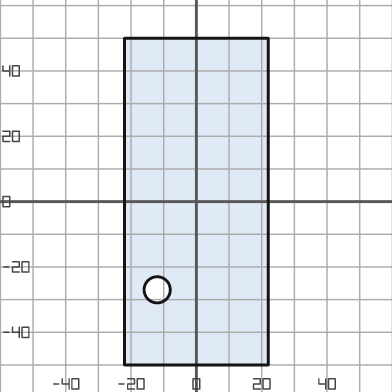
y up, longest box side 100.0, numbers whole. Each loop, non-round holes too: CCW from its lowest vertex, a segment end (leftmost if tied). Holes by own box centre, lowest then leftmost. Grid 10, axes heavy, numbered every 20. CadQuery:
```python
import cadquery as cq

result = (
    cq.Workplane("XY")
    .moveTo(-22.0, -50.0)
    .lineTo(22.0, -50.0)
    .lineTo(22.0, 50.0)
    .lineTo(-22.0, 50.0)
    .close()
    .moveTo(-12.0, -27.0)
    .circle(4.0)
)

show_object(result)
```